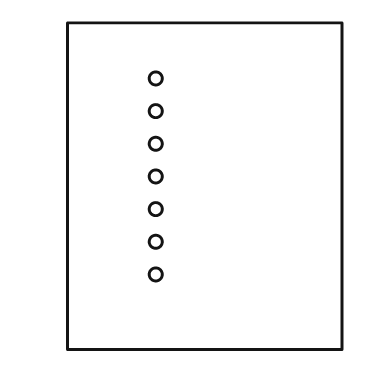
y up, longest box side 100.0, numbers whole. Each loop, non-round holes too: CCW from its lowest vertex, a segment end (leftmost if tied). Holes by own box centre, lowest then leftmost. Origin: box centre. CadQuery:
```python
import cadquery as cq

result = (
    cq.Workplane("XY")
    .moveTo(-42.0, -50.0)
    .lineTo(42.0, -50.0)
    .lineTo(42.0, 50.0)
    .lineTo(-42.0, 50.0)
    .close()
    .moveTo(-15.0, -27.0)
    .circle(2.0)
    .moveTo(-15.0, -17.0)
    .circle(2.0)
    .moveTo(-15.0, -7.0)
    .circle(2.0)
    .moveTo(-15.0, 3.0)
    .circle(2.0)
    .moveTo(-15.0, 13.0)
    .circle(2.0)
    .moveTo(-15.0, 23.0)
    .circle(2.0)
    .moveTo(-15.0, 33.0)
    .circle(2.0)
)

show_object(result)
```